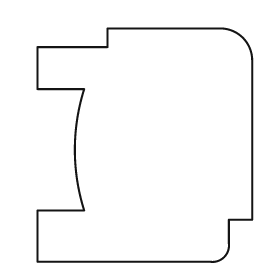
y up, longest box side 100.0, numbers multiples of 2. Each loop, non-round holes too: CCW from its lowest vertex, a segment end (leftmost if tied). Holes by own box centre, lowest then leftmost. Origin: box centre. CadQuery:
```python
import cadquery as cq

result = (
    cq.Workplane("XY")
    .moveTo(-46.0, -50.0)
    .lineTo(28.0, -50.0)
    .threePointArc((34.0, -48.0), (36.0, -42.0))
    .lineTo(36.0, -32.0)
    .lineTo(46.0, -32.0)
    .lineTo(46.0, 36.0)
    .threePointArc((42.0, 46.0), (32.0, 50.0))
    .lineTo(-16.0, 50.0)
    .lineTo(-16.0, 42.0)
    .lineTo(-46.0, 42.0)
    .lineTo(-46.0, 24.0)
    .lineTo(-26.0, 24.0)
    .threePointArc((-30.0, -2.0), (-26.0, -28.0))
    .lineTo(-46.0, -28.0)
    .close()
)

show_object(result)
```